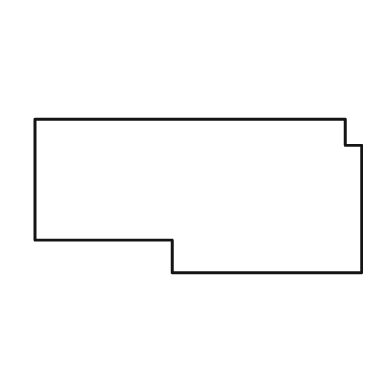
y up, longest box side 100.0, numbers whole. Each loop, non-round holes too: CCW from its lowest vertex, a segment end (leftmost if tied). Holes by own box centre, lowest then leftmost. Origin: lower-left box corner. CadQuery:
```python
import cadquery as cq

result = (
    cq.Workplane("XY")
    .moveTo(42.0, 0.0)
    .lineTo(100.0, 0.0)
    .lineTo(100.0, 39.0)
    .lineTo(95.0, 39.0)
    .lineTo(95.0, 47.0)
    .lineTo(0.0, 47.0)
    .lineTo(0.0, 10.0)
    .lineTo(42.0, 10.0)
    .close()
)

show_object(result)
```